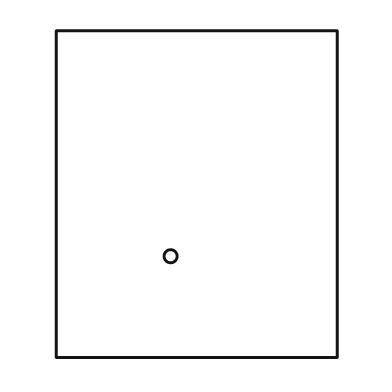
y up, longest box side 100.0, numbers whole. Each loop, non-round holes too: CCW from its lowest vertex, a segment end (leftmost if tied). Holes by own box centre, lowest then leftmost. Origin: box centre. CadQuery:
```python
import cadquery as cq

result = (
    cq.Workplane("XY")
    .moveTo(-43.0, -50.0)
    .lineTo(43.0, -50.0)
    .lineTo(43.0, 50.0)
    .lineTo(-43.0, 50.0)
    .close()
    .moveTo(-8.0, -19.0)
    .circle(2.0)
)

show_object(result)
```